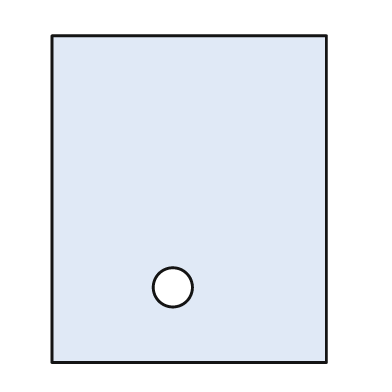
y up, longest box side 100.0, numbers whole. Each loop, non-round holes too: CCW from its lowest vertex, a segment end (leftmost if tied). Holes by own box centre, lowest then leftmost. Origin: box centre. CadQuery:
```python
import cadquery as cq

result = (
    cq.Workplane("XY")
    .moveTo(-42.0, -50.0)
    .lineTo(42.0, -50.0)
    .lineTo(42.0, 50.0)
    .lineTo(-42.0, 50.0)
    .close()
    .moveTo(-5.0, -27.0)
    .circle(6.0)
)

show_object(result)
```